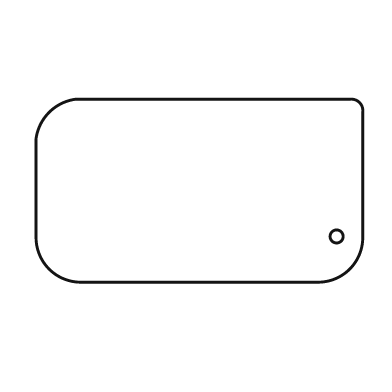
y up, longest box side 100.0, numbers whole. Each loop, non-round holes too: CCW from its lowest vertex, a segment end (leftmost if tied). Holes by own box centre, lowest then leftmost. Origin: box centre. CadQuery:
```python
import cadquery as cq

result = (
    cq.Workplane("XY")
    .moveTo(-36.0, -28.0)
    .lineTo(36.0, -28.0)
    .threePointArc((46.0, -24.0), (50.0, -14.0))
    .lineTo(50.0, 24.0)
    .threePointArc((49.0, 27.0), (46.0, 28.0))
    .lineTo(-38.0, 28.0)
    .threePointArc((-46.0, 24.0), (-50.0, 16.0))
    .lineTo(-50.0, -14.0)
    .threePointArc((-46.0, -24.0), (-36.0, -28.0))
    .close()
    .moveTo(42.0, -14.0)
    .circle(2.0)
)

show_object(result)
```